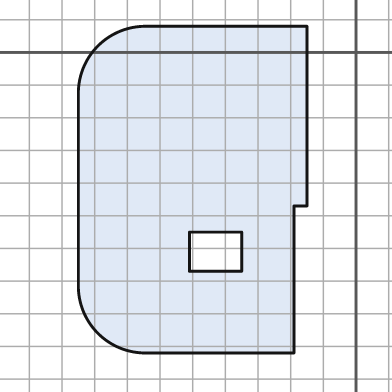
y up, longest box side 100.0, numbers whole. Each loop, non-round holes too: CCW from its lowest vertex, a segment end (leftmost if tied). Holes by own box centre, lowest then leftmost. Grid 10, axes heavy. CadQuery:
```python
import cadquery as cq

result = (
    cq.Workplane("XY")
    .moveTo(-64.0, -92.0)
    .lineTo(-19.0, -92.0)
    .lineTo(-19.0, -47.0)
    .lineTo(-15.0, -47.0)
    .lineTo(-15.0, 8.0)
    .lineTo(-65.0, 8.0)
    .threePointArc((-79.0, 2.0), (-85.0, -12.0))
    .lineTo(-85.0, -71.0)
    .threePointArc((-79.0, -86.0), (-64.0, -92.0))
    .close()
    .moveTo(-51.0, -67.0)
    .lineTo(-35.0, -67.0)
    .lineTo(-35.0, -55.0)
    .lineTo(-51.0, -55.0)
    .close()
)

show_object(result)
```